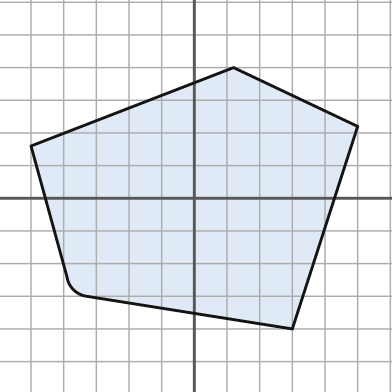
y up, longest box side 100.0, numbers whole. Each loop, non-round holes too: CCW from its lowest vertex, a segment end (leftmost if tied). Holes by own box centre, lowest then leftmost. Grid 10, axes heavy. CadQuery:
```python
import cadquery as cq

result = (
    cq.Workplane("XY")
    .moveTo(30.0, -40.0)
    .lineTo(50.0, 22.0)
    .lineTo(12.0, 40.0)
    .lineTo(-50.0, 16.0)
    .lineTo(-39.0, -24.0)
    .threePointArc((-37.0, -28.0), (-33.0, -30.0))
    .close()
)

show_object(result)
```